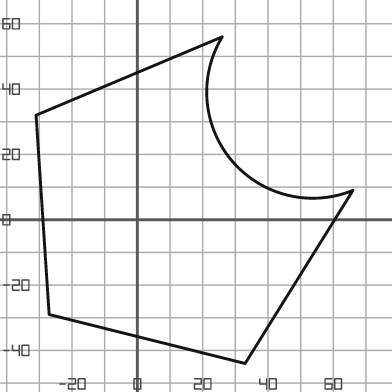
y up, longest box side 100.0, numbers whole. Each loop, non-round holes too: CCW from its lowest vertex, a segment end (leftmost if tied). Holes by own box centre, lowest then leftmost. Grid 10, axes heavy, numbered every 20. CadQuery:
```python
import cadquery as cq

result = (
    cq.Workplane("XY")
    .moveTo(33.0, -44.0)
    .lineTo(66.0, 9.0)
    .threePointArc((29.0, 18.0), (26.0, 56.0))
    .lineTo(-31.0, 32.0)
    .lineTo(-27.0, -29.0)
    .close()
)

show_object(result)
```